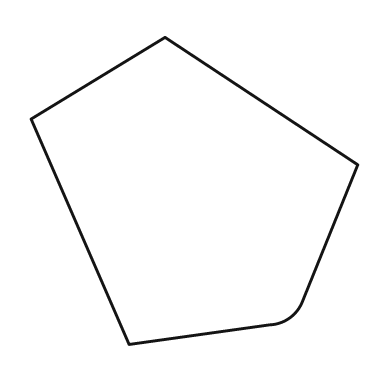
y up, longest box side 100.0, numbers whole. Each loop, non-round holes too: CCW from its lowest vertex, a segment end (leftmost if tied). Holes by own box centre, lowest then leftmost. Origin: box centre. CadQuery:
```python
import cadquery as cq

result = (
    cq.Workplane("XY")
    .moveTo(-20.0, -47.0)
    .lineTo(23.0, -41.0)
    .threePointArc((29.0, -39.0), (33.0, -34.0))
    .lineTo(50.0, 8.0)
    .lineTo(-9.0, 47.0)
    .lineTo(-50.0, 22.0)
    .close()
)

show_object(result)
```